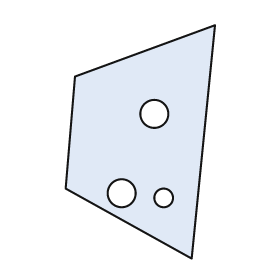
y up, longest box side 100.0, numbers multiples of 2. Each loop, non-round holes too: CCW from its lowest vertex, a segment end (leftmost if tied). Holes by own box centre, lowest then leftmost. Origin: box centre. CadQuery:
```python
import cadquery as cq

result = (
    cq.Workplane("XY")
    .moveTo(22.0, -50.0)
    .lineTo(32.0, 50.0)
    .lineTo(-28.0, 28.0)
    .lineTo(-32.0, -20.0)
    .close()
    .moveTo(10.0, -24.0)
    .circle(4.0)
    .moveTo(-8.0, -22.0)
    .circle(6.0)
    .moveTo(6.0, 12.0)
    .circle(6.0)
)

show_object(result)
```